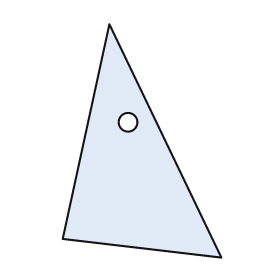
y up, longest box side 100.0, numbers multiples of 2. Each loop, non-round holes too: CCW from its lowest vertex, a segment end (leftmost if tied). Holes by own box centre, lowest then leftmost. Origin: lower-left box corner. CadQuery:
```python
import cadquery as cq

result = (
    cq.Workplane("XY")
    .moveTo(68.0, 0.0)
    .lineTo(20.0, 100.0)
    .lineTo(0.0, 8.0)
    .close()
    .moveTo(28.0, 58.0)
    .circle(4.0)
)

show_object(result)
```